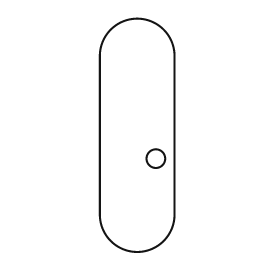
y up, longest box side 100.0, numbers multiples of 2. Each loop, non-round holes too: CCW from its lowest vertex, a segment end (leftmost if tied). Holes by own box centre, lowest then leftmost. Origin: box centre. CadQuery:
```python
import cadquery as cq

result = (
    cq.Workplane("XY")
    .moveTo(-16.0, -34.0)
    .threePointArc((0.0, -50.0), (16.0, -34.0))
    .lineTo(16.0, 34.0)
    .threePointArc((0.0, 50.0), (-16.0, 34.0))
    .close()
    .moveTo(8.0, -10.0)
    .circle(4.0)
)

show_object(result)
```